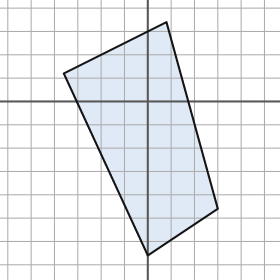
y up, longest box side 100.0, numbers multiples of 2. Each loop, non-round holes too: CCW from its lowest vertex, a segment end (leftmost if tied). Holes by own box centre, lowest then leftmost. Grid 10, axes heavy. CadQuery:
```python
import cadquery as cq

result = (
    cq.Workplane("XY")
    .moveTo(0.0, -66.0)
    .lineTo(30.0, -46.0)
    .lineTo(8.0, 34.0)
    .lineTo(-36.0, 12.0)
    .close()
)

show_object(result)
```